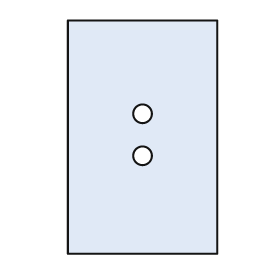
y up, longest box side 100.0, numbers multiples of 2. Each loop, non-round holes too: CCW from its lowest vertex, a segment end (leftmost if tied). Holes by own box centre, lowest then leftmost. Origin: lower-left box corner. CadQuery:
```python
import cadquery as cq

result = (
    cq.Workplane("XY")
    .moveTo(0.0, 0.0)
    .lineTo(64.0, 0.0)
    .lineTo(64.0, 100.0)
    .lineTo(0.0, 100.0)
    .close()
    .moveTo(32.0, 42.0)
    .circle(4.0)
    .moveTo(32.0, 60.0)
    .circle(4.0)
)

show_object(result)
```